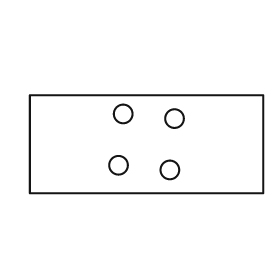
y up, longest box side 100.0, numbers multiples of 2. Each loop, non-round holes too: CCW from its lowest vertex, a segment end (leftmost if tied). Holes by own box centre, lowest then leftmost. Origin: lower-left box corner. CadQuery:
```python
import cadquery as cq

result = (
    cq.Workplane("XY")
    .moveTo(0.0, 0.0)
    .lineTo(100.0, 0.0)
    .lineTo(100.0, 42.0)
    .lineTo(0.0, 42.0)
    .close()
    .moveTo(60.0, 10.0)
    .circle(4.0)
    .moveTo(38.0, 12.0)
    .circle(4.0)
    .moveTo(62.0, 32.0)
    .circle(4.0)
    .moveTo(40.0, 34.0)
    .circle(4.0)
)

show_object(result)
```